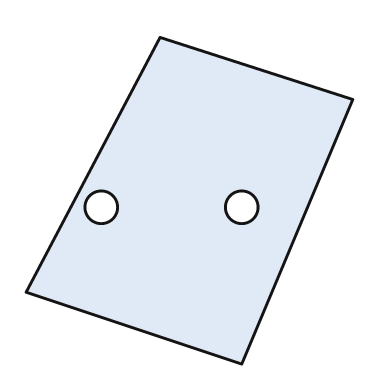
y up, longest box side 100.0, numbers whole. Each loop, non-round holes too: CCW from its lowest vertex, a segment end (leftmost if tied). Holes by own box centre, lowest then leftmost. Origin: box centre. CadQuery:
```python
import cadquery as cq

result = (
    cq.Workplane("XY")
    .moveTo(16.0, -50.0)
    .lineTo(50.0, 31.0)
    .lineTo(-9.0, 50.0)
    .lineTo(-50.0, -28.0)
    .close()
    .moveTo(-27.0, -2.0)
    .circle(5.0)
    .moveTo(16.0, -2.0)
    .circle(5.0)
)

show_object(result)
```